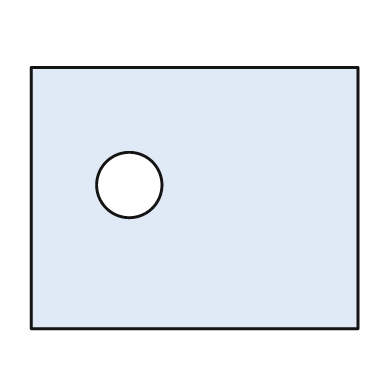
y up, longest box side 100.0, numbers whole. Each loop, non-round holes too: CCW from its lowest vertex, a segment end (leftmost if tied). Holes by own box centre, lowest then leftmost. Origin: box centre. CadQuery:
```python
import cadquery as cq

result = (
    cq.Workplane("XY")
    .moveTo(-50.0, -40.0)
    .lineTo(50.0, -40.0)
    .lineTo(50.0, 40.0)
    .lineTo(-50.0, 40.0)
    .close()
    .moveTo(-20.0, 4.0)
    .circle(10.0)
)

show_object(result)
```